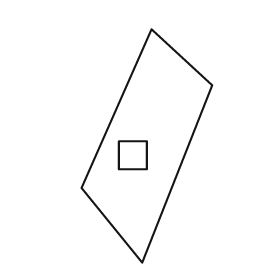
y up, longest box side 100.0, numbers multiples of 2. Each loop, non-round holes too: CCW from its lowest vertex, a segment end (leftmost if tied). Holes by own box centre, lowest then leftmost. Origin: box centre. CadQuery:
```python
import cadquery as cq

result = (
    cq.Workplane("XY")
    .moveTo(-2.0, -50.0)
    .lineTo(28.0, 26.0)
    .lineTo(2.0, 50.0)
    .lineTo(-28.0, -18.0)
    .close()
    .moveTo(-12.0, -10.0)
    .lineTo(0.0, -10.0)
    .lineTo(0.0, 2.0)
    .lineTo(-12.0, 2.0)
    .close()
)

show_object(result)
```